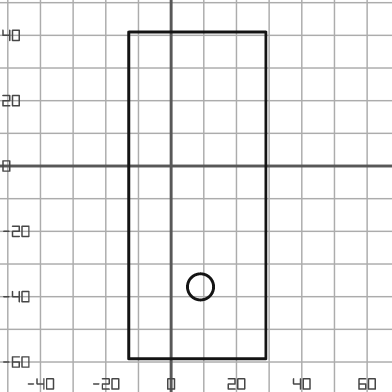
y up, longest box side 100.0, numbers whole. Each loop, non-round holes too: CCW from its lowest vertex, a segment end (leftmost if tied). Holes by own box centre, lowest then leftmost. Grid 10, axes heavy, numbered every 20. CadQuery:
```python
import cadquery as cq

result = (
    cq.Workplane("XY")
    .moveTo(-13.0, -59.0)
    .lineTo(29.0, -59.0)
    .lineTo(29.0, 41.0)
    .lineTo(-13.0, 41.0)
    .close()
    .moveTo(9.0, -37.0)
    .circle(4.0)
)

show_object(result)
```